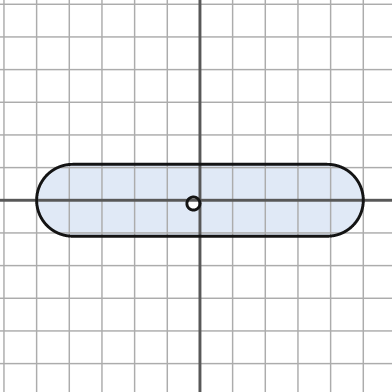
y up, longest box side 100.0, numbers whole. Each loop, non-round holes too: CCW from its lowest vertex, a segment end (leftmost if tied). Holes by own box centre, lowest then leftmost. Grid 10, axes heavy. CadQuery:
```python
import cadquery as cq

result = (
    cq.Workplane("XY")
    .moveTo(-39.0, -11.0)
    .lineTo(39.0, -11.0)
    .threePointArc((50.0, 0.0), (39.0, 11.0))
    .lineTo(-39.0, 11.0)
    .threePointArc((-50.0, 0.0), (-39.0, -11.0))
    .close()
    .moveTo(-2.0, -1.0)
    .circle(2.0)
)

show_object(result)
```